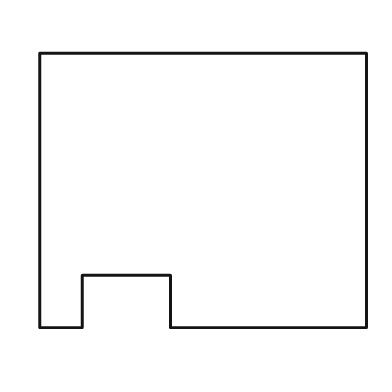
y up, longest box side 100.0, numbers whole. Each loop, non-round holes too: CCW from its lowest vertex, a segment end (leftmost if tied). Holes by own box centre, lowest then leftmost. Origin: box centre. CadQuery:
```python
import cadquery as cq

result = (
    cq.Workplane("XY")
    .moveTo(-50.0, -42.0)
    .lineTo(-37.0, -42.0)
    .lineTo(-37.0, -26.0)
    .lineTo(-10.0, -26.0)
    .lineTo(-10.0, -42.0)
    .lineTo(50.0, -42.0)
    .lineTo(50.0, 42.0)
    .lineTo(-50.0, 42.0)
    .close()
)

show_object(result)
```